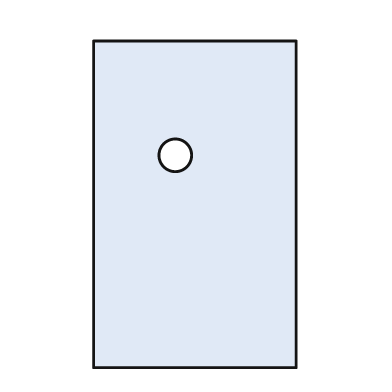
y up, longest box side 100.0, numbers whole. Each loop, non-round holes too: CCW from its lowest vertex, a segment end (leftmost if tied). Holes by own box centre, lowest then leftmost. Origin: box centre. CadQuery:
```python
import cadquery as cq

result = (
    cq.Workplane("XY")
    .moveTo(-31.0, -50.0)
    .lineTo(31.0, -50.0)
    .lineTo(31.0, 50.0)
    .lineTo(-31.0, 50.0)
    .close()
    .moveTo(-6.0, 15.0)
    .circle(5.0)
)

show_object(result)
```